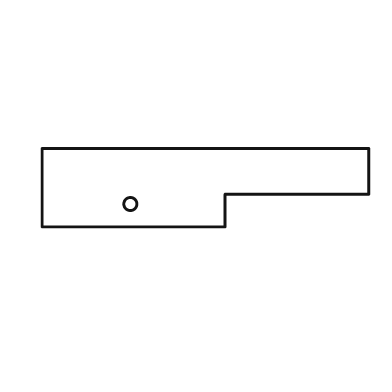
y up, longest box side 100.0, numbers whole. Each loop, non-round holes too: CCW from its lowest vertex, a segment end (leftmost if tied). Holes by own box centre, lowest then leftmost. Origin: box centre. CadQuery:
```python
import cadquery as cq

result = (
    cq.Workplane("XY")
    .moveTo(-50.0, -12.0)
    .lineTo(6.0, -12.0)
    .lineTo(6.0, -2.0)
    .lineTo(50.0, -2.0)
    .lineTo(50.0, 12.0)
    .lineTo(-50.0, 12.0)
    .close()
    .moveTo(-23.0, -5.0)
    .circle(2.0)
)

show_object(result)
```